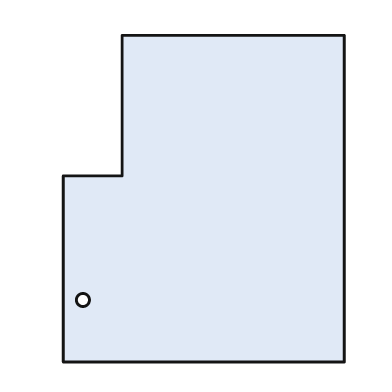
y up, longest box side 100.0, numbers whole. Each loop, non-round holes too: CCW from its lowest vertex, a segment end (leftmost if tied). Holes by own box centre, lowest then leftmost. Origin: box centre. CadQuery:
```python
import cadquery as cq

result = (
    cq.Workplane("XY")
    .moveTo(-43.0, -50.0)
    .lineTo(43.0, -50.0)
    .lineTo(43.0, 50.0)
    .lineTo(-25.0, 50.0)
    .lineTo(-25.0, 7.0)
    .lineTo(-43.0, 7.0)
    .close()
    .moveTo(-37.0, -31.0)
    .circle(2.0)
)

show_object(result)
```